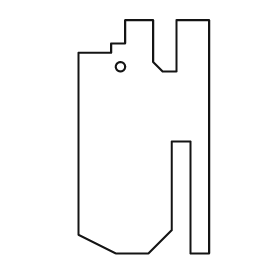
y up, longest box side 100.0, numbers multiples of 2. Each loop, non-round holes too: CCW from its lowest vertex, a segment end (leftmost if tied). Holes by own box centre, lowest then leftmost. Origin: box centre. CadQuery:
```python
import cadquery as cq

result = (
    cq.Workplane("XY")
    .moveTo(-12.0, -50.0)
    .lineTo(2.0, -50.0)
    .lineTo(12.0, -40.0)
    .lineTo(12.0, -2.0)
    .lineTo(20.0, -2.0)
    .lineTo(20.0, -50.0)
    .lineTo(28.0, -50.0)
    .lineTo(28.0, 50.0)
    .lineTo(14.0, 50.0)
    .lineTo(14.0, 28.0)
    .lineTo(8.0, 28.0)
    .lineTo(4.0, 32.0)
    .lineTo(4.0, 50.0)
    .lineTo(-8.0, 50.0)
    .lineTo(-8.0, 40.0)
    .lineTo(-14.0, 40.0)
    .lineTo(-14.0, 36.0)
    .lineTo(-28.0, 36.0)
    .lineTo(-28.0, -42.0)
    .close()
    .moveTo(-10.0, 30.0)
    .circle(2.0)
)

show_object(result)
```